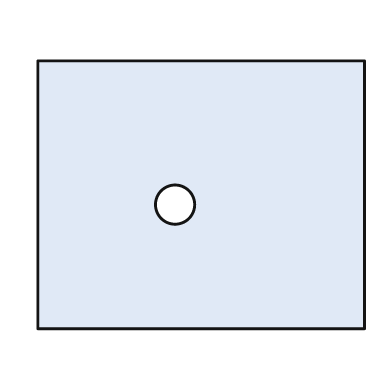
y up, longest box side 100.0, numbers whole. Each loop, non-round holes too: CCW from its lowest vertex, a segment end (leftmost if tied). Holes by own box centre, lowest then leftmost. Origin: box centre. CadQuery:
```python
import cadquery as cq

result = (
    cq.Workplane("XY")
    .moveTo(-50.0, -41.0)
    .lineTo(50.0, -41.0)
    .lineTo(50.0, 41.0)
    .lineTo(-50.0, 41.0)
    .close()
    .moveTo(-8.0, -3.0)
    .circle(6.0)
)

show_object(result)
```